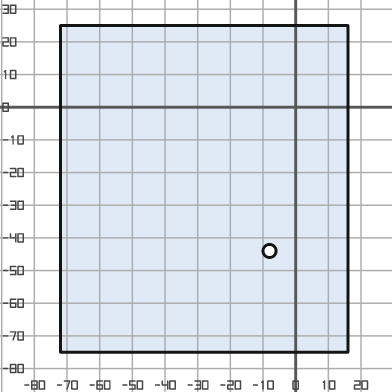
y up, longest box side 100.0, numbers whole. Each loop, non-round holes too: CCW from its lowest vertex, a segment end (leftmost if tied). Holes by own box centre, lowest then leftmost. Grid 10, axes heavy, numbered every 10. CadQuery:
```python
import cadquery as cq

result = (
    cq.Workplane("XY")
    .moveTo(-72.0, -75.0)
    .lineTo(16.0, -75.0)
    .lineTo(16.0, 25.0)
    .lineTo(-72.0, 25.0)
    .close()
    .moveTo(-8.0, -44.0)
    .circle(2.0)
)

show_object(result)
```